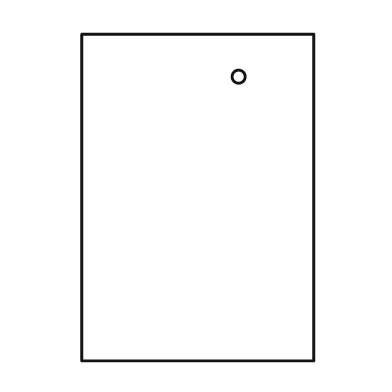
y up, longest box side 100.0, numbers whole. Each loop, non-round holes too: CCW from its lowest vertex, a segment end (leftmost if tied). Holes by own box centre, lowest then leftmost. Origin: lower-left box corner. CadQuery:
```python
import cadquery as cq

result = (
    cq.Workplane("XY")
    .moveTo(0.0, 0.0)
    .lineTo(71.0, 0.0)
    .lineTo(71.0, 100.0)
    .lineTo(0.0, 100.0)
    .close()
    .moveTo(48.0, 87.0)
    .circle(2.0)
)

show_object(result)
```